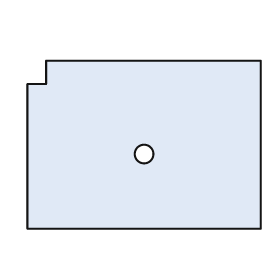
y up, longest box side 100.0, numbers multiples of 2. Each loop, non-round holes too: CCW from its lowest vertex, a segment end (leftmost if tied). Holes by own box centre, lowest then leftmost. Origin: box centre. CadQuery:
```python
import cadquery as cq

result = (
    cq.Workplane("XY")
    .moveTo(-50.0, -36.0)
    .lineTo(50.0, -36.0)
    .lineTo(50.0, 36.0)
    .lineTo(-42.0, 36.0)
    .lineTo(-42.0, 26.0)
    .lineTo(-50.0, 26.0)
    .close()
    .moveTo(0.0, -4.0)
    .circle(4.0)
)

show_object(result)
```